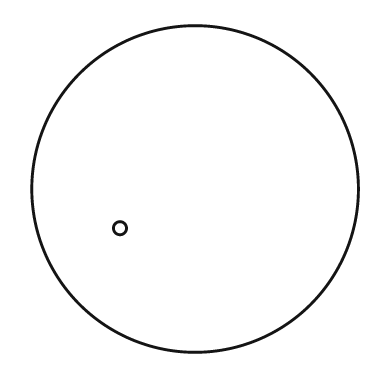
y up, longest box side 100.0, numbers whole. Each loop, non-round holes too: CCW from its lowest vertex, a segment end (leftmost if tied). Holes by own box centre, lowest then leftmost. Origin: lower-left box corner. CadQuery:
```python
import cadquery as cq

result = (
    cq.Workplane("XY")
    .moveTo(50.0, 50.0)
    .circle(50.0)
    .moveTo(27.0, 38.0)
    .circle(2.0)
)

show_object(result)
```